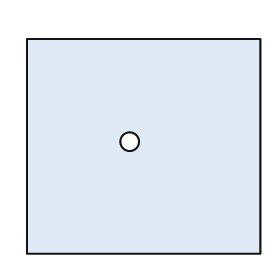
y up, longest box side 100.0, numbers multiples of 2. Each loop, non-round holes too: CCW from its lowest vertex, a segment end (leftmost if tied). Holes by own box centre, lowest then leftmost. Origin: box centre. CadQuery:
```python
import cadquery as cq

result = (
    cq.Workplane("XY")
    .moveTo(-50.0, -46.0)
    .lineTo(50.0, -46.0)
    .lineTo(50.0, 46.0)
    .lineTo(-50.0, 46.0)
    .close()
    .moveTo(-6.0, 2.0)
    .circle(4.0)
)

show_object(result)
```